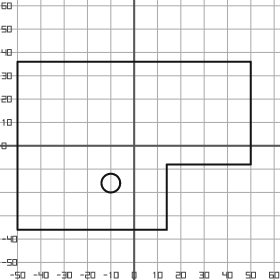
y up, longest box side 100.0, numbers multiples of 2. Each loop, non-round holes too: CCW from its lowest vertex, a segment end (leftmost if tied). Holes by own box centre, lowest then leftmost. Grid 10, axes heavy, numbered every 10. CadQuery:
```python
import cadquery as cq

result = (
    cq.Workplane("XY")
    .moveTo(-50.0, -36.0)
    .lineTo(14.0, -36.0)
    .lineTo(14.0, -8.0)
    .lineTo(50.0, -8.0)
    .lineTo(50.0, 36.0)
    .lineTo(-50.0, 36.0)
    .close()
    .moveTo(-10.0, -16.0)
    .circle(4.0)
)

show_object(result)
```